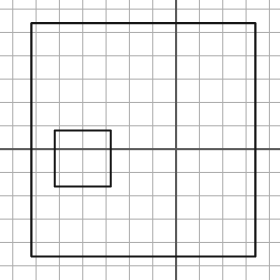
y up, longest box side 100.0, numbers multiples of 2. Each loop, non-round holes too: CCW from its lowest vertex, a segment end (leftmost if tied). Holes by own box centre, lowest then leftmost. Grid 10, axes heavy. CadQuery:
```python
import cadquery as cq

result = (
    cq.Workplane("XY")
    .moveTo(-62.0, -46.0)
    .lineTo(34.0, -46.0)
    .lineTo(34.0, 54.0)
    .lineTo(-62.0, 54.0)
    .close()
    .moveTo(-52.0, -16.0)
    .lineTo(-28.0, -16.0)
    .lineTo(-28.0, 8.0)
    .lineTo(-52.0, 8.0)
    .close()
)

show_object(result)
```